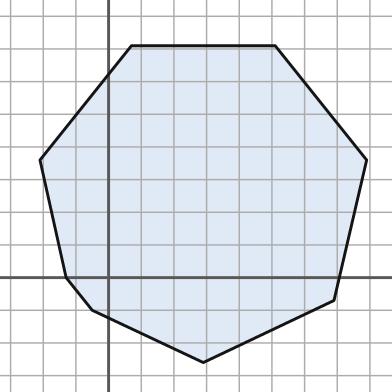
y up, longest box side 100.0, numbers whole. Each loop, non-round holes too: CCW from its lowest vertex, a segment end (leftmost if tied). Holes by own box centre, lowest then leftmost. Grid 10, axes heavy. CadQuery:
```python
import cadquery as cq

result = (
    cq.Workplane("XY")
    .moveTo(29.0, -26.0)
    .lineTo(69.0, -7.0)
    .lineTo(79.0, 36.0)
    .lineTo(51.0, 71.0)
    .lineTo(7.0, 71.0)
    .lineTo(-21.0, 36.0)
    .lineTo(-13.0, 0.0)
    .lineTo(-5.0, -10.0)
    .close()
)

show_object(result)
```